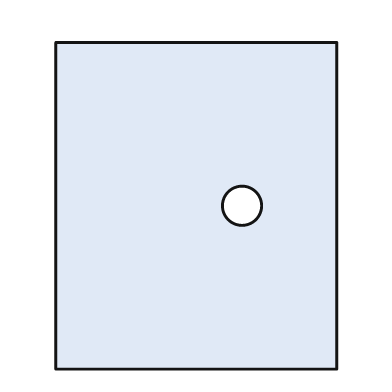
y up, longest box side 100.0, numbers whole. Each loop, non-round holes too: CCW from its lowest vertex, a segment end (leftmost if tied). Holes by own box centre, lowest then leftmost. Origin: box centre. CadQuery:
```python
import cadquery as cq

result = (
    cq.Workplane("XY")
    .moveTo(-43.0, -50.0)
    .lineTo(43.0, -50.0)
    .lineTo(43.0, 50.0)
    .lineTo(-43.0, 50.0)
    .close()
    .moveTo(14.0, 0.0)
    .circle(6.0)
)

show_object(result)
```